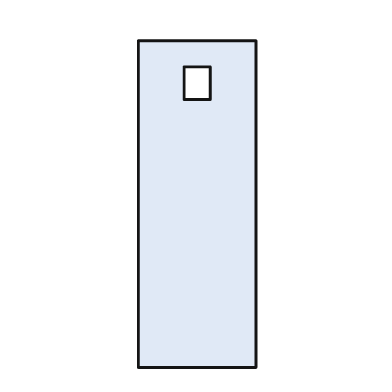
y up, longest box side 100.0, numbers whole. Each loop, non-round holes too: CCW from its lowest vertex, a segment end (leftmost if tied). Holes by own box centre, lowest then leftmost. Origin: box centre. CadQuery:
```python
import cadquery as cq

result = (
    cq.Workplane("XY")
    .moveTo(-18.0, -50.0)
    .lineTo(18.0, -50.0)
    .lineTo(18.0, 50.0)
    .lineTo(-18.0, 50.0)
    .close()
    .moveTo(-4.0, 32.0)
    .lineTo(4.0, 32.0)
    .lineTo(4.0, 42.0)
    .lineTo(-4.0, 42.0)
    .close()
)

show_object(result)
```